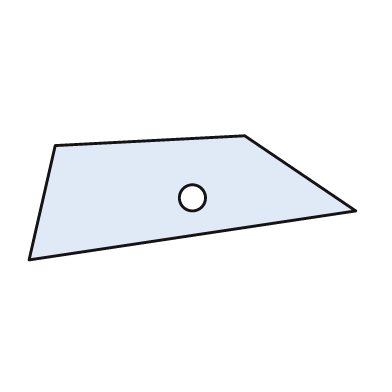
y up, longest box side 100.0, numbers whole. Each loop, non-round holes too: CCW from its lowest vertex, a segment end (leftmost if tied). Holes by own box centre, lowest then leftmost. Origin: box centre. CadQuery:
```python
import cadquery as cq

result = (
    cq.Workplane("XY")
    .moveTo(-50.0, -19.0)
    .lineTo(50.0, -4.0)
    .lineTo(16.0, 19.0)
    .lineTo(-42.0, 16.0)
    .close()
    .moveTo(0.0, 0.0)
    .circle(4.0)
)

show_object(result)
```